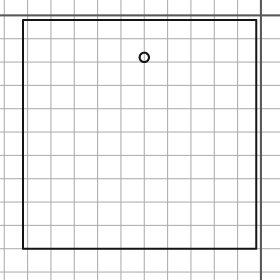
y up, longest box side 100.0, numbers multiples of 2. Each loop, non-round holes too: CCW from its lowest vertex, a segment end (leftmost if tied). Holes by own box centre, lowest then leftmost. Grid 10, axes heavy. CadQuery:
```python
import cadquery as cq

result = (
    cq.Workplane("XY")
    .moveTo(-102.0, -100.0)
    .lineTo(-2.0, -100.0)
    .lineTo(-2.0, -2.0)
    .lineTo(-102.0, -2.0)
    .close()
    .moveTo(-50.0, -18.0)
    .circle(2.0)
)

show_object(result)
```